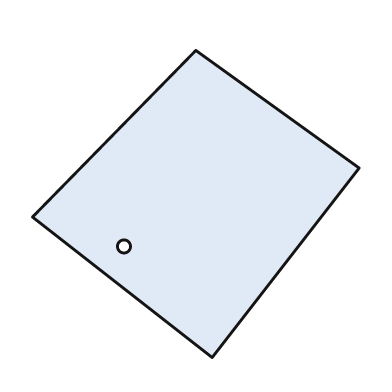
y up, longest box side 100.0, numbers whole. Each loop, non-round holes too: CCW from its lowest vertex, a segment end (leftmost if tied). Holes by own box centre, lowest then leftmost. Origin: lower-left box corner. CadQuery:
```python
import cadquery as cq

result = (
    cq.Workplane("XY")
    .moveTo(55.0, 0.0)
    .lineTo(100.0, 58.0)
    .lineTo(50.0, 94.0)
    .lineTo(0.0, 43.0)
    .close()
    .moveTo(28.0, 34.0)
    .circle(2.0)
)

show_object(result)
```